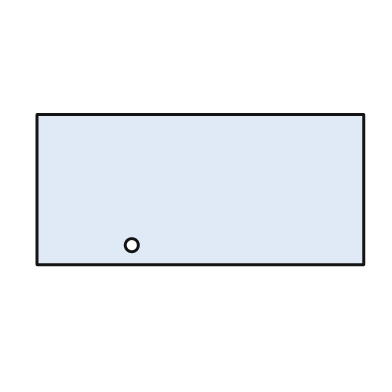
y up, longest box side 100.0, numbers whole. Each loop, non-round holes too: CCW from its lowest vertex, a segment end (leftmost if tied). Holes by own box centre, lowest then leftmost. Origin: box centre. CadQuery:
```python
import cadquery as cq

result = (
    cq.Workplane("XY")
    .moveTo(-50.0, -23.0)
    .lineTo(50.0, -23.0)
    .lineTo(50.0, 23.0)
    .lineTo(-50.0, 23.0)
    .close()
    .moveTo(-21.0, -17.0)
    .circle(2.0)
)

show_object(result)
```